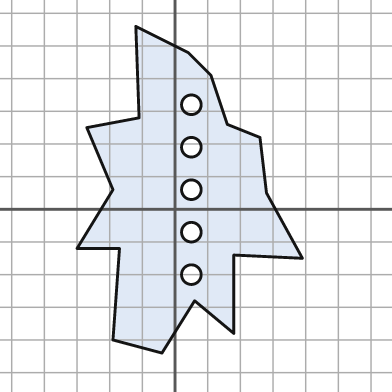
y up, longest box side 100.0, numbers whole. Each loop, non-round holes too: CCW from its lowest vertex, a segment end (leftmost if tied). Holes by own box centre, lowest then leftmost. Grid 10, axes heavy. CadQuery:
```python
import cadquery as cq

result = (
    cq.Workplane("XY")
    .moveTo(-4.0, -44.0)
    .lineTo(6.0, -28.0)
    .lineTo(18.0, -38.0)
    .lineTo(18.0, -14.0)
    .lineTo(39.0, -15.0)
    .lineTo(28.0, 5.0)
    .lineTo(26.0, 22.0)
    .lineTo(16.0, 26.0)
    .lineTo(11.0, 41.0)
    .lineTo(4.0, 48.0)
    .lineTo(-12.0, 56.0)
    .lineTo(-11.0, 28.0)
    .lineTo(-27.0, 25.0)
    .lineTo(-19.0, 6.0)
    .lineTo(-30.0, -12.0)
    .lineTo(-17.0, -12.0)
    .lineTo(-19.0, -40.0)
    .close()
    .moveTo(5.0, -20.0)
    .circle(3.0)
    .moveTo(5.0, -7.0)
    .circle(3.0)
    .moveTo(5.0, 6.0)
    .circle(3.0)
    .moveTo(5.0, 19.0)
    .circle(3.0)
    .moveTo(5.0, 32.0)
    .circle(3.0)
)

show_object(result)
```